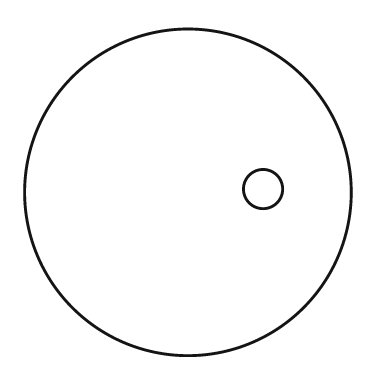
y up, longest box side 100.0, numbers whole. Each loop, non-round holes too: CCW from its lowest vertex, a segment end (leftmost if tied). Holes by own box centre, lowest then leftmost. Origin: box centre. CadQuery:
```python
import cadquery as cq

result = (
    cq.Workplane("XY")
    .moveTo(0.0, 0.0)
    .circle(50.0)
    .moveTo(23.0, 1.0)
    .circle(6.0)
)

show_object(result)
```